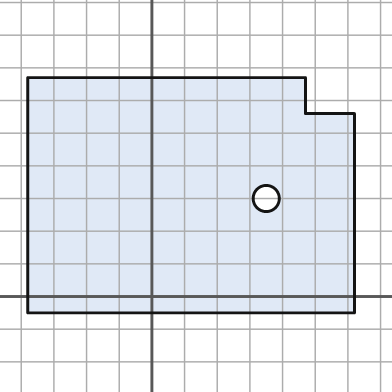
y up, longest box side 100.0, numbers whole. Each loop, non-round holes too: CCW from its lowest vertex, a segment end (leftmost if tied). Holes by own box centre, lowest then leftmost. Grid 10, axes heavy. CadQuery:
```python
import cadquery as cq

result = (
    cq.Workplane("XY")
    .moveTo(-38.0, -5.0)
    .lineTo(62.0, -5.0)
    .lineTo(62.0, 56.0)
    .lineTo(47.0, 56.0)
    .lineTo(47.0, 67.0)
    .lineTo(-38.0, 67.0)
    .close()
    .moveTo(35.0, 30.0)
    .circle(4.0)
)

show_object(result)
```